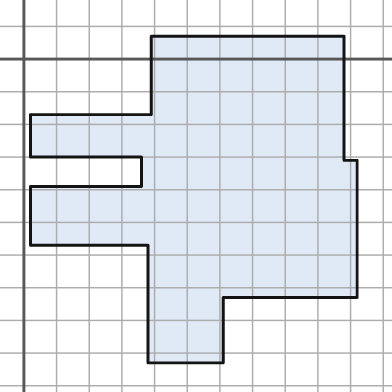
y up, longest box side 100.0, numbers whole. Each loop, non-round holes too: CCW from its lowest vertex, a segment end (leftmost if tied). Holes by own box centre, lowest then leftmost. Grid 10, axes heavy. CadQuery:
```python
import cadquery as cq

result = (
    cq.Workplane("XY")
    .moveTo(38.0, -93.0)
    .lineTo(61.0, -93.0)
    .lineTo(61.0, -73.0)
    .lineTo(102.0, -73.0)
    .lineTo(102.0, -31.0)
    .lineTo(98.0, -31.0)
    .lineTo(98.0, 7.0)
    .lineTo(39.0, 7.0)
    .lineTo(39.0, -17.0)
    .lineTo(2.0, -17.0)
    .lineTo(2.0, -30.0)
    .lineTo(36.0, -30.0)
    .lineTo(36.0, -39.0)
    .lineTo(2.0, -39.0)
    .lineTo(2.0, -57.0)
    .lineTo(38.0, -57.0)
    .close()
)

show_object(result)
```